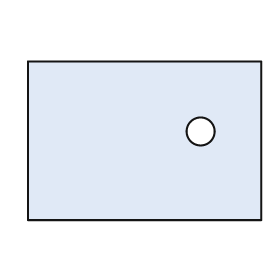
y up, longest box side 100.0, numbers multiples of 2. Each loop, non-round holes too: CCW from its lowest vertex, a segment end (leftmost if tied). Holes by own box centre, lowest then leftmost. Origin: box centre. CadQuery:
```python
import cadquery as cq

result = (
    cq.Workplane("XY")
    .moveTo(-50.0, -34.0)
    .lineTo(50.0, -34.0)
    .lineTo(50.0, 34.0)
    .lineTo(-50.0, 34.0)
    .close()
    .moveTo(24.0, 4.0)
    .circle(6.0)
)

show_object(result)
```